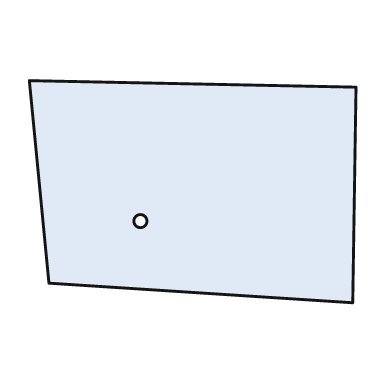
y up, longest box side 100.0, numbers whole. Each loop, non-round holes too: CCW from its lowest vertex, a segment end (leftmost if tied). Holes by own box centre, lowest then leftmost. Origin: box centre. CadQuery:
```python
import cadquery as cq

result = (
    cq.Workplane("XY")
    .moveTo(49.0, -34.0)
    .lineTo(50.0, 32.0)
    .lineTo(-50.0, 34.0)
    .lineTo(-44.0, -28.0)
    .close()
    .moveTo(-16.0, -9.0)
    .circle(2.0)
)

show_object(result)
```